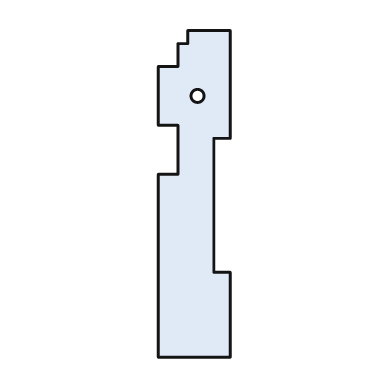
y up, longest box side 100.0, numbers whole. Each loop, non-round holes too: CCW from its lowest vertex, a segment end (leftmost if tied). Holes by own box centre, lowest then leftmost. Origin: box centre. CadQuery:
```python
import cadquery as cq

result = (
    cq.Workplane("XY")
    .moveTo(-11.0, -50.0)
    .lineTo(11.0, -50.0)
    .lineTo(11.0, -24.0)
    .lineTo(6.0, -24.0)
    .lineTo(6.0, 17.0)
    .lineTo(11.0, 17.0)
    .lineTo(11.0, 50.0)
    .lineTo(-2.0, 50.0)
    .lineTo(-2.0, 46.0)
    .lineTo(-5.0, 46.0)
    .lineTo(-5.0, 39.0)
    .lineTo(-11.0, 39.0)
    .lineTo(-11.0, 21.0)
    .lineTo(-5.0, 21.0)
    .lineTo(-5.0, 6.0)
    .lineTo(-11.0, 6.0)
    .close()
    .moveTo(1.0, 30.0)
    .circle(2.0)
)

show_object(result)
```